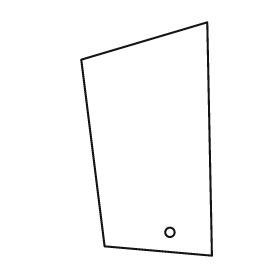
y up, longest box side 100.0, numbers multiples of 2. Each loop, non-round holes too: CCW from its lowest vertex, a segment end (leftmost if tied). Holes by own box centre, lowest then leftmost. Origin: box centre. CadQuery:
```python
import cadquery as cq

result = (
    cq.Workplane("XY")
    .moveTo(28.0, -50.0)
    .lineTo(26.0, 50.0)
    .lineTo(-28.0, 34.0)
    .lineTo(-18.0, -46.0)
    .close()
    .moveTo(10.0, -40.0)
    .circle(2.0)
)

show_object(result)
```